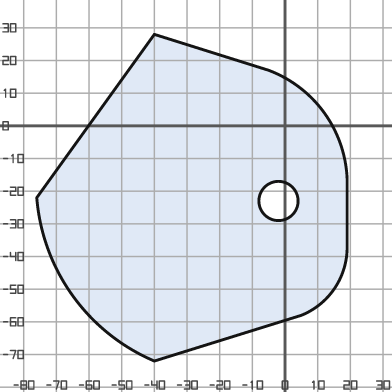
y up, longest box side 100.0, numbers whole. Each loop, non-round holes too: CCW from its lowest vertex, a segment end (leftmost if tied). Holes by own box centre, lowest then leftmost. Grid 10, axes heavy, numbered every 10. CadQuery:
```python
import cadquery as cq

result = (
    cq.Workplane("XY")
    .moveTo(-40.0, -72.0)
    .lineTo(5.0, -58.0)
    .threePointArc((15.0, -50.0), (19.0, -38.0))
    .lineTo(19.0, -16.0)
    .threePointArc((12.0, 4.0), (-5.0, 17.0))
    .lineTo(-40.0, 28.0)
    .lineTo(-76.0, -22.0)
    .threePointArc((-65.0, -52.0), (-40.0, -72.0))
    .close()
    .moveTo(-2.0, -23.0)
    .circle(6.0)
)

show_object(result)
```